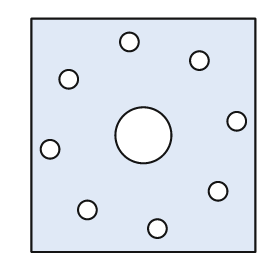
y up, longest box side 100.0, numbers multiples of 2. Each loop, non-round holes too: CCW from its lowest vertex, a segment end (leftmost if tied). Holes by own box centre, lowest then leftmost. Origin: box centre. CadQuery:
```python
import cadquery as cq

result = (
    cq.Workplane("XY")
    .moveTo(-48.0, -50.0)
    .lineTo(48.0, -50.0)
    .lineTo(48.0, 50.0)
    .lineTo(-48.0, 50.0)
    .close()
    .moveTo(6.0, -40.0)
    .circle(4.0)
    .moveTo(-24.0, -32.0)
    .circle(4.0)
    .moveTo(32.0, -24.0)
    .circle(4.0)
    .moveTo(-40.0, -6.0)
    .circle(4.0)
    .moveTo(0.0, 0.0)
    .circle(12.0)
    .moveTo(40.0, 6.0)
    .circle(4.0)
    .moveTo(-32.0, 24.0)
    .circle(4.0)
    .moveTo(24.0, 32.0)
    .circle(4.0)
    .moveTo(-6.0, 40.0)
    .circle(4.0)
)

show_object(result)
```